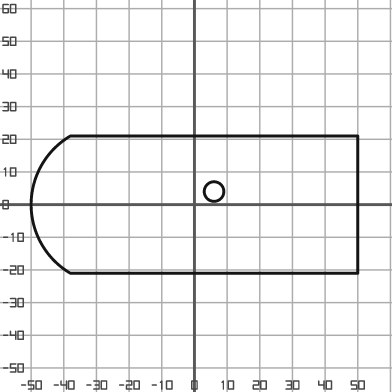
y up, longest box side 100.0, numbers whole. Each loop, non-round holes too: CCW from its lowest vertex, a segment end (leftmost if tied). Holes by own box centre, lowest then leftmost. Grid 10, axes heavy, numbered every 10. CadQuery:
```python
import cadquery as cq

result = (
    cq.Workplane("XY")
    .moveTo(-38.0, -21.0)
    .lineTo(50.0, -21.0)
    .lineTo(50.0, 21.0)
    .lineTo(-38.0, 21.0)
    .threePointArc((-50.0, 0.0), (-38.0, -21.0))
    .close()
    .moveTo(6.0, 4.0)
    .circle(3.0)
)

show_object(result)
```